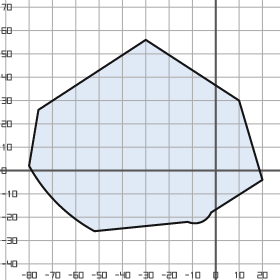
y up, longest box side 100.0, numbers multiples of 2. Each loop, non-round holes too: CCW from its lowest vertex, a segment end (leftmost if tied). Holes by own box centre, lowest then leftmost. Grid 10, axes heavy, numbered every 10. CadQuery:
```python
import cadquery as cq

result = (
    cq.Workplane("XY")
    .moveTo(-52.0, -26.0)
    .lineTo(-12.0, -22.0)
    .threePointArc((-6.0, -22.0), (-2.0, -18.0))
    .lineTo(20.0, -4.0)
    .lineTo(10.0, 30.0)
    .lineTo(-30.0, 56.0)
    .lineTo(-76.0, 26.0)
    .lineTo(-80.0, 2.0)
    .threePointArc((-68.0, -14.0), (-52.0, -26.0))
    .close()
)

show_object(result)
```